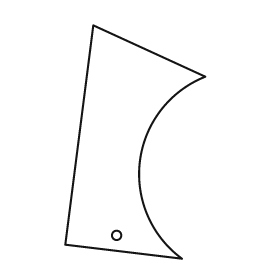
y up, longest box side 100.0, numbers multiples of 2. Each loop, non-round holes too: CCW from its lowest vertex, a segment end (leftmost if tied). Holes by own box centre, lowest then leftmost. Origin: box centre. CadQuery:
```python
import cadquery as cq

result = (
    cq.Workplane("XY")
    .moveTo(20.0, -50.0)
    .threePointArc((2.0, -8.0), (30.0, 28.0))
    .lineTo(-18.0, 50.0)
    .lineTo(-30.0, -44.0)
    .close()
    .moveTo(-8.0, -40.0)
    .circle(2.0)
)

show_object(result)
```